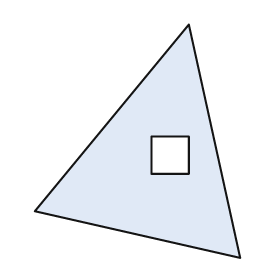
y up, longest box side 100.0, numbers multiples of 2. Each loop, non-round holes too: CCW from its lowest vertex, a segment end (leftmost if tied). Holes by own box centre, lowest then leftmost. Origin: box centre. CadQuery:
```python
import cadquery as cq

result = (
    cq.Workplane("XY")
    .moveTo(44.0, -50.0)
    .lineTo(22.0, 50.0)
    .lineTo(-44.0, -30.0)
    .close()
    .moveTo(6.0, -14.0)
    .lineTo(22.0, -14.0)
    .lineTo(22.0, 2.0)
    .lineTo(6.0, 2.0)
    .close()
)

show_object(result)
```